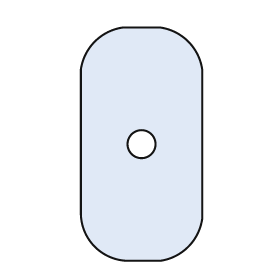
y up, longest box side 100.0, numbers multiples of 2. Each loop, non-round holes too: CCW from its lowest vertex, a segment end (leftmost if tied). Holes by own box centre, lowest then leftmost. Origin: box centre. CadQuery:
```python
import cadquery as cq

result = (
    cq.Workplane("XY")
    .moveTo(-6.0, -50.0)
    .lineTo(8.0, -50.0)
    .threePointArc((20.0, -44.0), (26.0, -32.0))
    .lineTo(26.0, 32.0)
    .threePointArc((20.0, 44.0), (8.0, 50.0))
    .lineTo(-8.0, 50.0)
    .threePointArc((-20.0, 44.0), (-26.0, 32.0))
    .lineTo(-26.0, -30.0)
    .threePointArc((-20.0, -44.0), (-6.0, -50.0))
    .close()
    .moveTo(0.0, 0.0)
    .circle(6.0)
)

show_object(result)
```